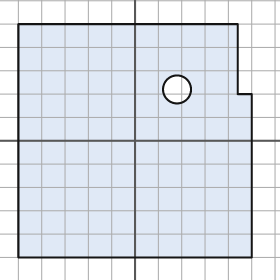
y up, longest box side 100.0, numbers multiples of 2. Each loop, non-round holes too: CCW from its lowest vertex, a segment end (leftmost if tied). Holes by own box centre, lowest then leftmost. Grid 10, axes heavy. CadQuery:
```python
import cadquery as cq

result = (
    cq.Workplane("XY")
    .moveTo(-50.0, -50.0)
    .lineTo(50.0, -50.0)
    .lineTo(50.0, 20.0)
    .lineTo(44.0, 20.0)
    .lineTo(44.0, 50.0)
    .lineTo(-50.0, 50.0)
    .close()
    .moveTo(18.0, 22.0)
    .circle(6.0)
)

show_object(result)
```